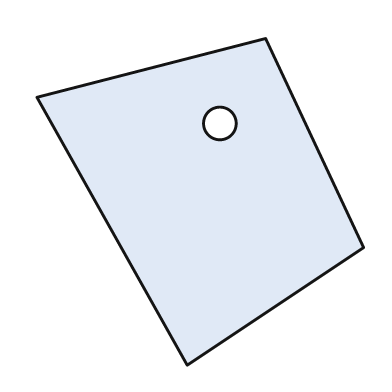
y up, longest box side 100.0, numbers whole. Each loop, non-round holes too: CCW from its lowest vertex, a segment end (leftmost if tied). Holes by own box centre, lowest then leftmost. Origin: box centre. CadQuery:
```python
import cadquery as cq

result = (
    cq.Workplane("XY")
    .moveTo(-4.0, -50.0)
    .lineTo(50.0, -14.0)
    .lineTo(20.0, 50.0)
    .lineTo(-50.0, 32.0)
    .close()
    .moveTo(6.0, 24.0)
    .circle(5.0)
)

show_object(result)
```